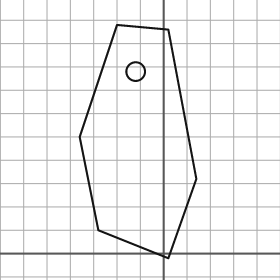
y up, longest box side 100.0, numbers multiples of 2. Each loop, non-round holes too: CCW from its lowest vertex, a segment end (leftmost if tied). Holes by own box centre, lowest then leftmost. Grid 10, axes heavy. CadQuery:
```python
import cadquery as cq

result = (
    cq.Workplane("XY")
    .moveTo(2.0, -2.0)
    .lineTo(14.0, 32.0)
    .lineTo(2.0, 96.0)
    .lineTo(-20.0, 98.0)
    .lineTo(-36.0, 50.0)
    .lineTo(-28.0, 10.0)
    .close()
    .moveTo(-12.0, 78.0)
    .circle(4.0)
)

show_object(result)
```